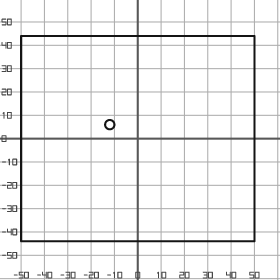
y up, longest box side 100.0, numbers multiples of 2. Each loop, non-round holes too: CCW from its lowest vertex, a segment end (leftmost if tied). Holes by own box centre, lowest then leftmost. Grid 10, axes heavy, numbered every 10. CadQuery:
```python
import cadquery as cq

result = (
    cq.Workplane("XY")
    .moveTo(-50.0, -44.0)
    .lineTo(50.0, -44.0)
    .lineTo(50.0, 44.0)
    .lineTo(-50.0, 44.0)
    .close()
    .moveTo(-12.0, 6.0)
    .circle(2.0)
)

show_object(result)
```